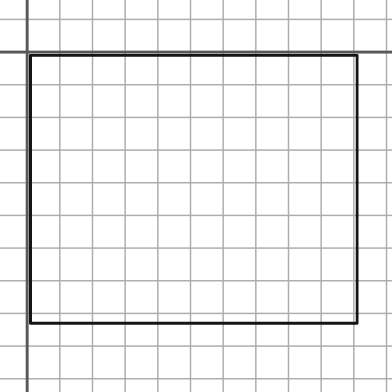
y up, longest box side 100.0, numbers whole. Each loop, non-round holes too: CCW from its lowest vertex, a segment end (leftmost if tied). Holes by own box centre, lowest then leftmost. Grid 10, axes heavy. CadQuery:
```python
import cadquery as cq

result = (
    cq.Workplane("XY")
    .moveTo(1.0, -83.0)
    .lineTo(101.0, -83.0)
    .lineTo(101.0, -1.0)
    .lineTo(1.0, -1.0)
    .close()
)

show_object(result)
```